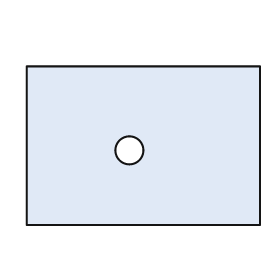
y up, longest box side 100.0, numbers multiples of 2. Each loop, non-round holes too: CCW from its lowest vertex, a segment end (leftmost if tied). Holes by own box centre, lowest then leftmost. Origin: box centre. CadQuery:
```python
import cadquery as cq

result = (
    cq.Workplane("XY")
    .moveTo(-50.0, -34.0)
    .lineTo(50.0, -34.0)
    .lineTo(50.0, 34.0)
    .lineTo(-50.0, 34.0)
    .close()
    .moveTo(-6.0, -2.0)
    .circle(6.0)
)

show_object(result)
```